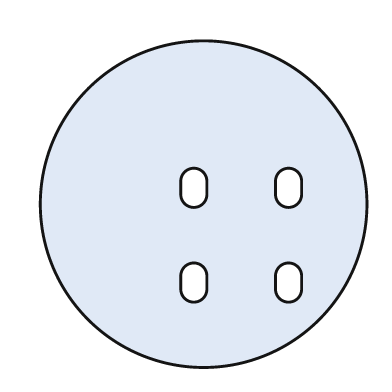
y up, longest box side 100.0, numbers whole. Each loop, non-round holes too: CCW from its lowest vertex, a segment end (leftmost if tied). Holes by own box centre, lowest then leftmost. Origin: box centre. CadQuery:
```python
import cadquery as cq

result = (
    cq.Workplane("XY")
    .moveTo(0.0, 0.0)
    .circle(50.0)
    .moveTo(-7.0, -26.0)
    .threePointArc((-3.0, -30.0), (1.0, -26.0))
    .lineTo(1.0, -22.0)
    .threePointArc((-3.0, -18.0), (-7.0, -22.0))
    .close()
    .moveTo(22.0, -26.0)
    .threePointArc((26.0, -30.0), (30.0, -26.0))
    .lineTo(30.0, -22.0)
    .threePointArc((26.0, -18.0), (22.0, -22.0))
    .close()
    .moveTo(-7.0, 3.0)
    .threePointArc((-3.0, -1.0), (1.0, 3.0))
    .lineTo(1.0, 7.0)
    .threePointArc((-3.0, 11.0), (-7.0, 7.0))
    .close()
    .moveTo(22.0, 3.0)
    .threePointArc((26.0, -1.0), (30.0, 3.0))
    .lineTo(30.0, 7.0)
    .threePointArc((26.0, 11.0), (22.0, 7.0))
    .close()
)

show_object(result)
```